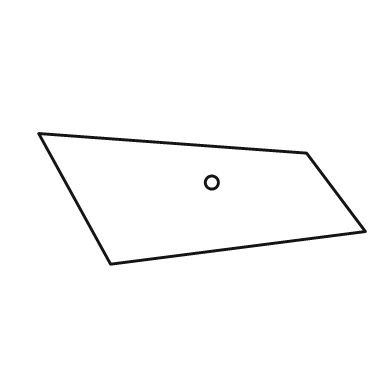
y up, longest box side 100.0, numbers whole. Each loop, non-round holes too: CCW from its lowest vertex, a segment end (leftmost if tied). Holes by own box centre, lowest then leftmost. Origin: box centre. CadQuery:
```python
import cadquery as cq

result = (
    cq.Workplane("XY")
    .moveTo(-28.0, -20.0)
    .lineTo(50.0, -10.0)
    .lineTo(32.0, 14.0)
    .lineTo(-50.0, 20.0)
    .close()
    .moveTo(3.0, 5.0)
    .circle(2.0)
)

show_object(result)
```